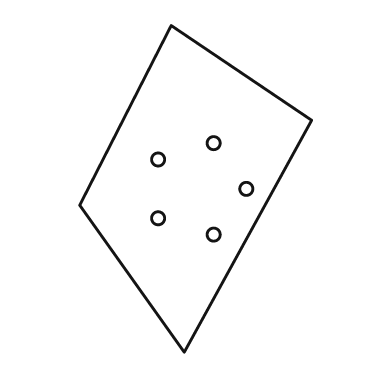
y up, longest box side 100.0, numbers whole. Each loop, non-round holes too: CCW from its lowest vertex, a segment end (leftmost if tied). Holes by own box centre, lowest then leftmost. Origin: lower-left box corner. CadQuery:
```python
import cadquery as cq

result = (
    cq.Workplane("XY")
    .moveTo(32.0, 0.0)
    .lineTo(71.0, 71.0)
    .lineTo(28.0, 100.0)
    .lineTo(0.0, 45.0)
    .close()
    .moveTo(41.0, 36.0)
    .circle(2.0)
    .moveTo(24.0, 41.0)
    .circle(2.0)
    .moveTo(51.0, 50.0)
    .circle(2.0)
    .moveTo(24.0, 59.0)
    .circle(2.0)
    .moveTo(41.0, 64.0)
    .circle(2.0)
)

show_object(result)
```